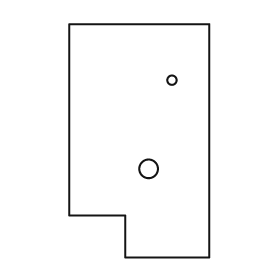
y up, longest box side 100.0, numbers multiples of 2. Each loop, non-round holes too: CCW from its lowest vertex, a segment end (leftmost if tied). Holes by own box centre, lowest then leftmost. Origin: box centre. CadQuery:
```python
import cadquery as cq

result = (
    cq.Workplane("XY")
    .moveTo(-6.0, -50.0)
    .lineTo(30.0, -50.0)
    .lineTo(30.0, 50.0)
    .lineTo(-30.0, 50.0)
    .lineTo(-30.0, -32.0)
    .lineTo(-6.0, -32.0)
    .close()
    .moveTo(4.0, -12.0)
    .circle(4.0)
    .moveTo(14.0, 26.0)
    .circle(2.0)
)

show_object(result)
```